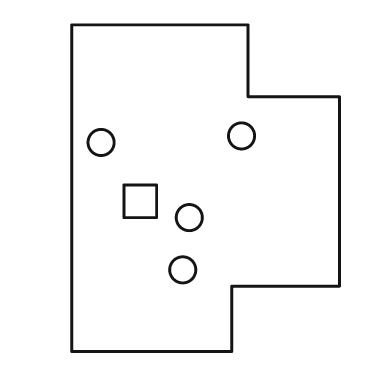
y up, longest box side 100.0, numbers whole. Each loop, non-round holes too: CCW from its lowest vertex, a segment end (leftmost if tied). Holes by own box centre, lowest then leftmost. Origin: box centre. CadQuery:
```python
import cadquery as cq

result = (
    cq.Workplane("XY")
    .moveTo(-41.0, -50.0)
    .lineTo(8.0, -50.0)
    .lineTo(8.0, -30.0)
    .lineTo(41.0, -30.0)
    .lineTo(41.0, 28.0)
    .lineTo(13.0, 28.0)
    .lineTo(13.0, 50.0)
    .lineTo(-41.0, 50.0)
    .close()
    .moveTo(-7.0, -25.0)
    .circle(4.0)
    .moveTo(-5.0, -9.0)
    .circle(4.0)
    .moveTo(-25.0, -9.0)
    .lineTo(-15.0, -9.0)
    .lineTo(-15.0, 1.0)
    .lineTo(-25.0, 1.0)
    .close()
    .moveTo(-32.0, 14.0)
    .circle(4.0)
    .moveTo(11.0, 16.0)
    .circle(4.0)
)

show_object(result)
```